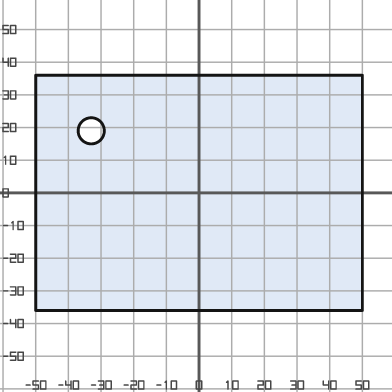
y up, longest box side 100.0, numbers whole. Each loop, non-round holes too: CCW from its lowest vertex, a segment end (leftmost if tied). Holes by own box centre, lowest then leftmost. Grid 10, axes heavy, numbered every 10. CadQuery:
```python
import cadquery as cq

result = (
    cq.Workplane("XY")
    .moveTo(-50.0, -36.0)
    .lineTo(50.0, -36.0)
    .lineTo(50.0, 36.0)
    .lineTo(-50.0, 36.0)
    .close()
    .moveTo(-33.0, 19.0)
    .circle(4.0)
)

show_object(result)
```